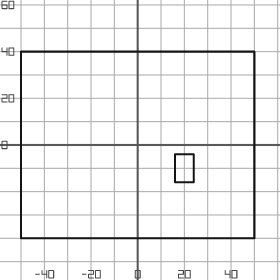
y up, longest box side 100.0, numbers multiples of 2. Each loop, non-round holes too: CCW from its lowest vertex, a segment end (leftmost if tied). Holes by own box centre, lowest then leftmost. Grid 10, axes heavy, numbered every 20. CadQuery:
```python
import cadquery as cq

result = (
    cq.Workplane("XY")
    .moveTo(-50.0, -40.0)
    .lineTo(50.0, -40.0)
    .lineTo(50.0, 40.0)
    .lineTo(-50.0, 40.0)
    .close()
    .moveTo(16.0, -16.0)
    .lineTo(24.0, -16.0)
    .lineTo(24.0, -4.0)
    .lineTo(16.0, -4.0)
    .close()
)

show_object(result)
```